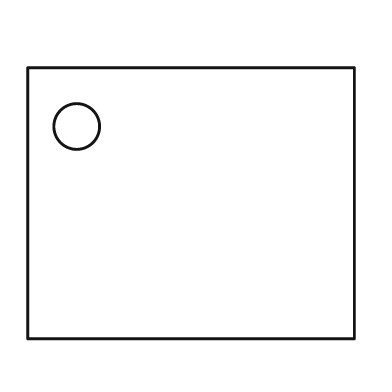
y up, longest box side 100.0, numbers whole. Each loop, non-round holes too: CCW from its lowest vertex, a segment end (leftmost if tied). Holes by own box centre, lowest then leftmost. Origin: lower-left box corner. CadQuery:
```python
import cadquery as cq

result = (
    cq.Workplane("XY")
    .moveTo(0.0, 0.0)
    .lineTo(100.0, 0.0)
    .lineTo(100.0, 83.0)
    .lineTo(0.0, 83.0)
    .close()
    .moveTo(15.0, 65.0)
    .circle(7.0)
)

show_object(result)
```